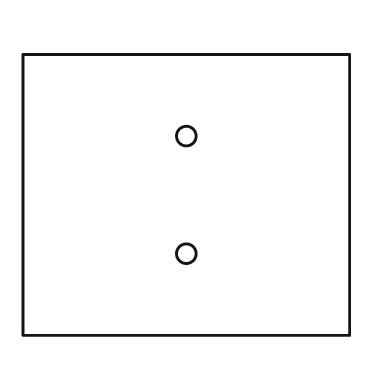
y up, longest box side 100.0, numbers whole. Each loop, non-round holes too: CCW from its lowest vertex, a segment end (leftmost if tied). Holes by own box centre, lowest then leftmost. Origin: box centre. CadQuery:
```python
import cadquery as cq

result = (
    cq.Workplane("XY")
    .moveTo(-50.0, -43.0)
    .lineTo(50.0, -43.0)
    .lineTo(50.0, 43.0)
    .lineTo(-50.0, 43.0)
    .close()
    .moveTo(0.0, -18.0)
    .circle(3.0)
    .moveTo(0.0, 18.0)
    .circle(3.0)
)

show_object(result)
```